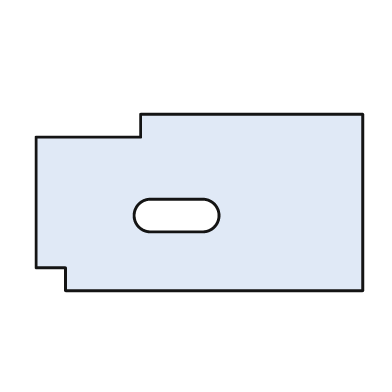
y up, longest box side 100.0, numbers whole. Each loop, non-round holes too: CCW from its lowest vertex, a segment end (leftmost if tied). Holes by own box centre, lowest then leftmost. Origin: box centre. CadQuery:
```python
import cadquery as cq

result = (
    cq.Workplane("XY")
    .moveTo(-41.0, -27.0)
    .lineTo(50.0, -27.0)
    .lineTo(50.0, 27.0)
    .lineTo(-18.0, 27.0)
    .lineTo(-18.0, 20.0)
    .lineTo(-50.0, 20.0)
    .lineTo(-50.0, -20.0)
    .lineTo(-41.0, -20.0)
    .close()
    .moveTo(-15.0, -9.0)
    .lineTo(1.0, -9.0)
    .threePointArc((6.0, -4.0), (1.0, 1.0))
    .lineTo(-15.0, 1.0)
    .threePointArc((-20.0, -4.0), (-15.0, -9.0))
    .close()
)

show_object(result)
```